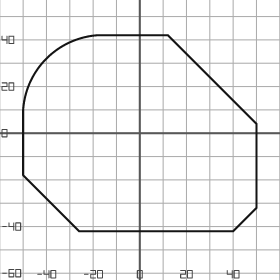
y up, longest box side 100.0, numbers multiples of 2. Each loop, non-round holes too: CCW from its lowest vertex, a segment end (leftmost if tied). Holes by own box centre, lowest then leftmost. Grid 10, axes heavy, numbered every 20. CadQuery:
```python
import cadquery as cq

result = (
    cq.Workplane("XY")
    .moveTo(-26.0, -42.0)
    .lineTo(40.0, -42.0)
    .lineTo(50.0, -32.0)
    .lineTo(50.0, 4.0)
    .lineTo(12.0, 42.0)
    .lineTo(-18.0, 42.0)
    .threePointArc((-40.0, 32.0), (-50.0, 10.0))
    .lineTo(-50.0, -18.0)
    .close()
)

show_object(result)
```